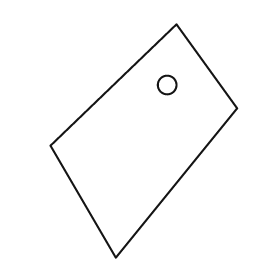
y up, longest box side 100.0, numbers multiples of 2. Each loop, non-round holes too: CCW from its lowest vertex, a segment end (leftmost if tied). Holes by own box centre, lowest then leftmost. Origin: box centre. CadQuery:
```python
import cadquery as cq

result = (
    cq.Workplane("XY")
    .moveTo(-12.0, -50.0)
    .lineTo(40.0, 14.0)
    .lineTo(14.0, 50.0)
    .lineTo(-40.0, -2.0)
    .close()
    .moveTo(10.0, 24.0)
    .circle(4.0)
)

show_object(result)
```